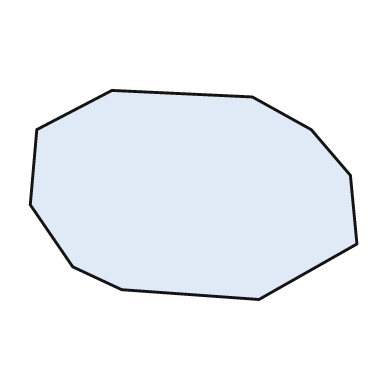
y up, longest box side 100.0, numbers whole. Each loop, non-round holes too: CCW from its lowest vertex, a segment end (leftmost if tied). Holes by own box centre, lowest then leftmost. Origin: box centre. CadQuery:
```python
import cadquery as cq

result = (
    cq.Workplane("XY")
    .moveTo(20.0, -32.0)
    .lineTo(50.0, -15.0)
    .lineTo(48.0, 6.0)
    .lineTo(36.0, 20.0)
    .lineTo(18.0, 30.0)
    .lineTo(-25.0, 32.0)
    .lineTo(-48.0, 20.0)
    .lineTo(-50.0, -3.0)
    .lineTo(-37.0, -22.0)
    .lineTo(-22.0, -29.0)
    .close()
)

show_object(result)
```